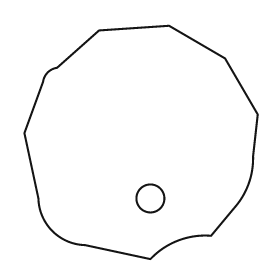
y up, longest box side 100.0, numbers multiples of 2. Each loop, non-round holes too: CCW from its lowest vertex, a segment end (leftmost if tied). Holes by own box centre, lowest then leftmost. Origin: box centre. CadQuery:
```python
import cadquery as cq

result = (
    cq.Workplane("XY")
    .moveTo(4.0, -50.0)
    .threePointArc((16.0, -42.0), (30.0, -40.0))
    .lineTo(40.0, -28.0)
    .threePointArc((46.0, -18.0), (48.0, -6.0))
    .lineTo(50.0, 12.0)
    .lineTo(36.0, 36.0)
    .lineTo(12.0, 50.0)
    .lineTo(-18.0, 48.0)
    .lineTo(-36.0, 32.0)
    .threePointArc((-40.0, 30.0), (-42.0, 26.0))
    .lineTo(-50.0, 4.0)
    .lineTo(-44.0, -24.0)
    .threePointArc((-38.0, -38.0), (-24.0, -44.0))
    .close()
    .moveTo(4.0, -24.0)
    .circle(6.0)
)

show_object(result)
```